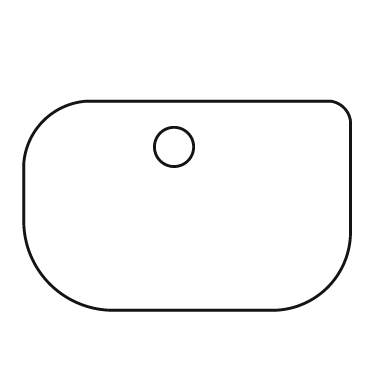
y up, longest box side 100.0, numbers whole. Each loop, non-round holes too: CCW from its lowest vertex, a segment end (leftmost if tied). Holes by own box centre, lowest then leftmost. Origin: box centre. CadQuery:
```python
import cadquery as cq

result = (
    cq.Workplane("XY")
    .moveTo(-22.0, -32.0)
    .lineTo(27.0, -32.0)
    .threePointArc((43.0, -25.0), (50.0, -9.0))
    .lineTo(50.0, 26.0)
    .threePointArc((48.0, 30.0), (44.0, 32.0))
    .lineTo(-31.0, 32.0)
    .threePointArc((-44.0, 26.0), (-50.0, 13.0))
    .lineTo(-50.0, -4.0)
    .threePointArc((-42.0, -24.0), (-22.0, -32.0))
    .close()
    .moveTo(-4.0, 18.0)
    .circle(6.0)
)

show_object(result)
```